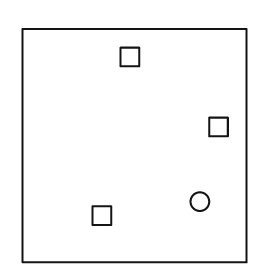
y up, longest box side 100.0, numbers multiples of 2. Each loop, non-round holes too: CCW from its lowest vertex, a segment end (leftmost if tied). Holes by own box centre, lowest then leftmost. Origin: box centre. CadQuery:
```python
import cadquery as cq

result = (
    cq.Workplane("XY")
    .moveTo(-48.0, -50.0)
    .lineTo(48.0, -50.0)
    .lineTo(48.0, 50.0)
    .lineTo(-48.0, 50.0)
    .close()
    .moveTo(-18.0, -34.0)
    .lineTo(-10.0, -34.0)
    .lineTo(-10.0, -26.0)
    .lineTo(-18.0, -26.0)
    .close()
    .moveTo(28.0, -24.0)
    .circle(4.0)
    .moveTo(32.0, 4.0)
    .lineTo(40.0, 4.0)
    .lineTo(40.0, 12.0)
    .lineTo(32.0, 12.0)
    .close()
    .moveTo(-6.0, 34.0)
    .lineTo(2.0, 34.0)
    .lineTo(2.0, 42.0)
    .lineTo(-6.0, 42.0)
    .close()
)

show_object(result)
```